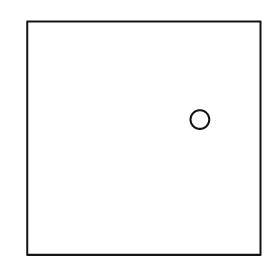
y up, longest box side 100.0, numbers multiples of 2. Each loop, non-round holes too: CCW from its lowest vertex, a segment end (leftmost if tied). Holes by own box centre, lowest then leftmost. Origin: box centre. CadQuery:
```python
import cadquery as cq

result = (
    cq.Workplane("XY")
    .moveTo(-50.0, -50.0)
    .lineTo(50.0, -50.0)
    .lineTo(50.0, 50.0)
    .lineTo(-50.0, 50.0)
    .close()
    .moveTo(24.0, 8.0)
    .circle(4.0)
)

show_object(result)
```